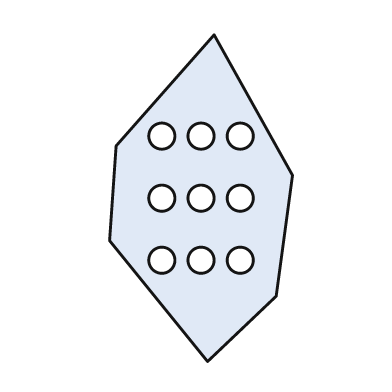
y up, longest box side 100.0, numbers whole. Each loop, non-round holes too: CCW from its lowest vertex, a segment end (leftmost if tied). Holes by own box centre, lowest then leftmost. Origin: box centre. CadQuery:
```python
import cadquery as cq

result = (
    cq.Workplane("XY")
    .moveTo(2.0, -50.0)
    .lineTo(23.0, -30.0)
    .lineTo(28.0, 7.0)
    .lineTo(4.0, 50.0)
    .lineTo(-26.0, 16.0)
    .lineTo(-28.0, -13.0)
    .close()
    .moveTo(-12.0, -19.0)
    .circle(4.0)
    .moveTo(0.0, -19.0)
    .circle(4.0)
    .moveTo(12.0, -19.0)
    .circle(4.0)
    .moveTo(-12.0, 0.0)
    .circle(4.0)
    .moveTo(0.0, 0.0)
    .circle(4.0)
    .moveTo(12.0, 0.0)
    .circle(4.0)
    .moveTo(-12.0, 19.0)
    .circle(4.0)
    .moveTo(0.0, 19.0)
    .circle(4.0)
    .moveTo(12.0, 19.0)
    .circle(4.0)
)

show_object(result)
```